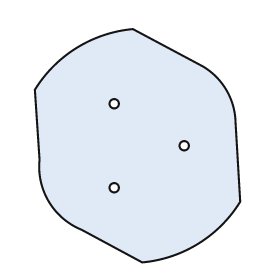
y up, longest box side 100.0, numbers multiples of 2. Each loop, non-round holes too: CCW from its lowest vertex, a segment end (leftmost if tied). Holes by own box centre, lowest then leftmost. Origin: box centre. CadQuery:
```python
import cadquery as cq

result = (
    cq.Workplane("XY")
    .moveTo(2.0, -50.0)
    .threePointArc((26.0, -42.0), (44.0, -24.0))
    .lineTo(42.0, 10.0)
    .threePointArc((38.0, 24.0), (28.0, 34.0))
    .lineTo(-2.0, 50.0)
    .threePointArc((-26.0, 42.0), (-44.0, 24.0))
    .lineTo(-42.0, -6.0)
    .threePointArc((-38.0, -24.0), (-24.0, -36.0))
    .close()
    .moveTo(-10.0, -18.0)
    .circle(2.0)
    .moveTo(20.0, 0.0)
    .circle(2.0)
    .moveTo(-10.0, 18.0)
    .circle(2.0)
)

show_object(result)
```